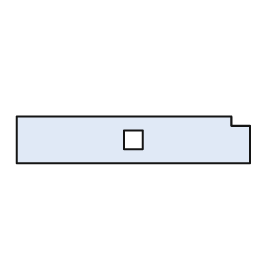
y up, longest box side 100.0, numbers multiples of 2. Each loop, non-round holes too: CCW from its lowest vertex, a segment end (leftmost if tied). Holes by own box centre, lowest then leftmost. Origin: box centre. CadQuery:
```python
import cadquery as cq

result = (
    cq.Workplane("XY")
    .moveTo(-50.0, -10.0)
    .lineTo(50.0, -10.0)
    .lineTo(50.0, 6.0)
    .lineTo(42.0, 6.0)
    .lineTo(42.0, 10.0)
    .lineTo(-50.0, 10.0)
    .close()
    .moveTo(-4.0, -4.0)
    .lineTo(4.0, -4.0)
    .lineTo(4.0, 4.0)
    .lineTo(-4.0, 4.0)
    .close()
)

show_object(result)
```